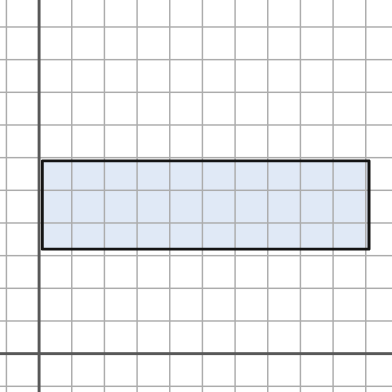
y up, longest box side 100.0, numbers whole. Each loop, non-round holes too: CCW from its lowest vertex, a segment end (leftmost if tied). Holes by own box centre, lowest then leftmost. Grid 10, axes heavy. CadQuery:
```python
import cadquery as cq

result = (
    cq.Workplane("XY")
    .moveTo(1.0, 32.0)
    .lineTo(101.0, 32.0)
    .lineTo(101.0, 59.0)
    .lineTo(1.0, 59.0)
    .close()
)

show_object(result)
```